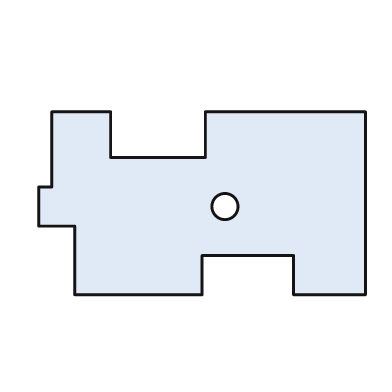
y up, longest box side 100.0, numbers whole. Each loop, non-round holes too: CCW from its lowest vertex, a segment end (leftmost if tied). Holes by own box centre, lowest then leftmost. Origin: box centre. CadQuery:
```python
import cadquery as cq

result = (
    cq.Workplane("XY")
    .moveTo(-39.0, -28.0)
    .lineTo(0.0, -28.0)
    .lineTo(0.0, -16.0)
    .lineTo(28.0, -16.0)
    .lineTo(28.0, -28.0)
    .lineTo(50.0, -28.0)
    .lineTo(50.0, 28.0)
    .lineTo(1.0, 28.0)
    .lineTo(1.0, 14.0)
    .lineTo(-28.0, 14.0)
    .lineTo(-28.0, 28.0)
    .lineTo(-46.0, 28.0)
    .lineTo(-46.0, 5.0)
    .lineTo(-50.0, 5.0)
    .lineTo(-50.0, -7.0)
    .lineTo(-39.0, -7.0)
    .close()
    .moveTo(7.0, -1.0)
    .circle(4.0)
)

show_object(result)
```